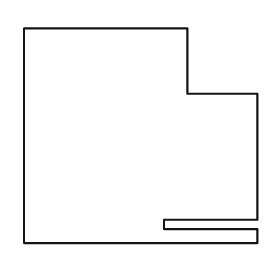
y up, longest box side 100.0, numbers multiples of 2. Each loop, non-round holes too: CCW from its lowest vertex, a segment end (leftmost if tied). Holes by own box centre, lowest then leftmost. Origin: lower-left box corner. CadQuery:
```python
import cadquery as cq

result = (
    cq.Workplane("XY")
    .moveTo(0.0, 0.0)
    .lineTo(100.0, 0.0)
    .lineTo(100.0, 6.0)
    .lineTo(60.0, 6.0)
    .lineTo(60.0, 10.0)
    .lineTo(100.0, 10.0)
    .lineTo(100.0, 64.0)
    .lineTo(70.0, 64.0)
    .lineTo(70.0, 92.0)
    .lineTo(0.0, 92.0)
    .close()
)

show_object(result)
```